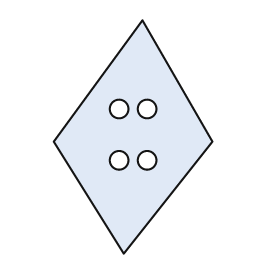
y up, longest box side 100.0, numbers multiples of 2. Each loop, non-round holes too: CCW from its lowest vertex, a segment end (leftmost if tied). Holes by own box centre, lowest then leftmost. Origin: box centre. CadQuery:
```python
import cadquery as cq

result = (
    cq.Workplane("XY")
    .moveTo(-4.0, -50.0)
    .lineTo(34.0, -2.0)
    .lineTo(4.0, 50.0)
    .lineTo(-34.0, -2.0)
    .close()
    .moveTo(-6.0, -10.0)
    .circle(4.0)
    .moveTo(6.0, -10.0)
    .circle(4.0)
    .moveTo(-6.0, 12.0)
    .circle(4.0)
    .moveTo(6.0, 12.0)
    .circle(4.0)
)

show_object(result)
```